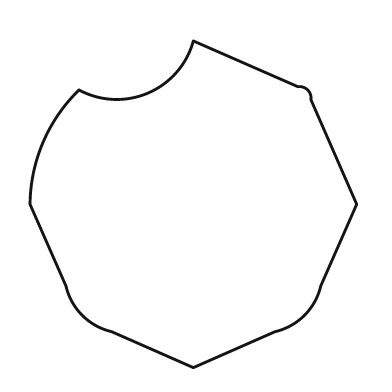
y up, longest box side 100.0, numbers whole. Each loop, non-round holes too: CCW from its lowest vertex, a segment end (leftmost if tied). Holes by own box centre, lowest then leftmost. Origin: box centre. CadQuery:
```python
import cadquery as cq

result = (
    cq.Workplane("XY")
    .moveTo(0.0, -50.0)
    .lineTo(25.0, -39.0)
    .threePointArc((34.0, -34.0), (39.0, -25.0))
    .lineTo(50.0, 0.0)
    .lineTo(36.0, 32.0)
    .threePointArc((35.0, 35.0), (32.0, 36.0))
    .lineTo(0.0, 50.0)
    .threePointArc((-14.0, 34.0), (-35.0, 35.0))
    .threePointArc((-46.0, 19.0), (-50.0, 0.0))
    .lineTo(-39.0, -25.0)
    .threePointArc((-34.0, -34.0), (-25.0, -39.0))
    .close()
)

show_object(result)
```